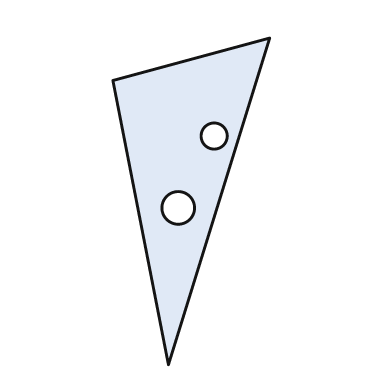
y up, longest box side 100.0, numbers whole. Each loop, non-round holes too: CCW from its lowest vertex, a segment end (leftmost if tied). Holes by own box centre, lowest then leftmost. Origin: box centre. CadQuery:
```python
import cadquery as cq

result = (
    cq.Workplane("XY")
    .moveTo(-7.0, -50.0)
    .lineTo(24.0, 50.0)
    .lineTo(-24.0, 37.0)
    .close()
    .moveTo(-4.0, -2.0)
    .circle(5.0)
    .moveTo(7.0, 20.0)
    .circle(4.0)
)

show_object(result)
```